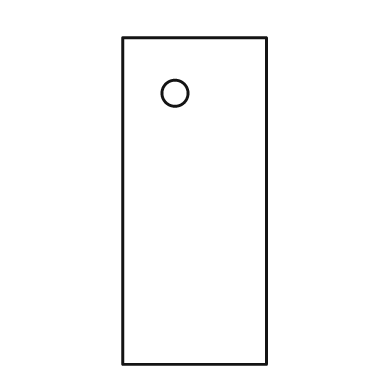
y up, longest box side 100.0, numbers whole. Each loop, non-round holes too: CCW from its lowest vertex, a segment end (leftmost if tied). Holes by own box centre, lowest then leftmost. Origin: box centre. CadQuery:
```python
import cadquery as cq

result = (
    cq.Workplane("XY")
    .moveTo(-22.0, -50.0)
    .lineTo(22.0, -50.0)
    .lineTo(22.0, 50.0)
    .lineTo(-22.0, 50.0)
    .close()
    .moveTo(-6.0, 33.0)
    .circle(4.0)
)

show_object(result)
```